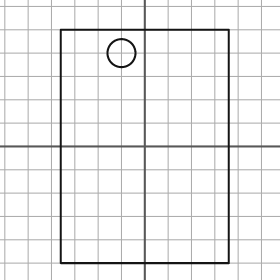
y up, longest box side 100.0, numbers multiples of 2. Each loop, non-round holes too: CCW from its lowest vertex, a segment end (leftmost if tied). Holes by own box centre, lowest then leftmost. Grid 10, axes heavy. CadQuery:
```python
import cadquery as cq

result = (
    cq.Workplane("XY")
    .moveTo(-36.0, -50.0)
    .lineTo(36.0, -50.0)
    .lineTo(36.0, 50.0)
    .lineTo(-36.0, 50.0)
    .close()
    .moveTo(-10.0, 40.0)
    .circle(6.0)
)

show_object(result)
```